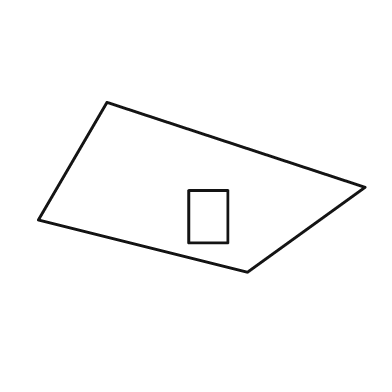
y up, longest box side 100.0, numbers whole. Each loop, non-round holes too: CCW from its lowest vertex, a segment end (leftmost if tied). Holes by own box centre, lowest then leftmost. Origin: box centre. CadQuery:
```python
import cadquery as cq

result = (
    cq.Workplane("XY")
    .moveTo(14.0, -26.0)
    .lineTo(50.0, 0.0)
    .lineTo(-29.0, 26.0)
    .lineTo(-50.0, -10.0)
    .close()
    .moveTo(-4.0, -17.0)
    .lineTo(8.0, -17.0)
    .lineTo(8.0, -1.0)
    .lineTo(-4.0, -1.0)
    .close()
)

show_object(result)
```